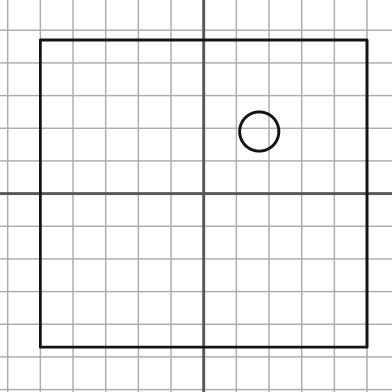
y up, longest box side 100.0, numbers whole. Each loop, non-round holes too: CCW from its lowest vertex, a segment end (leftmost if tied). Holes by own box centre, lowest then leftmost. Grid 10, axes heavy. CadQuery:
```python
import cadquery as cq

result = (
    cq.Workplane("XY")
    .moveTo(-50.0, -47.0)
    .lineTo(50.0, -47.0)
    .lineTo(50.0, 47.0)
    .lineTo(-50.0, 47.0)
    .close()
    .moveTo(17.0, 19.0)
    .circle(6.0)
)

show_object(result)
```